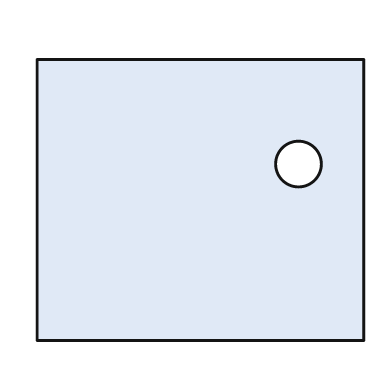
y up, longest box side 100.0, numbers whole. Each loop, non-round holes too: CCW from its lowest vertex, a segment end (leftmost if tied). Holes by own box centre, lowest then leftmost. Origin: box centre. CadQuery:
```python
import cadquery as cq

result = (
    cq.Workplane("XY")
    .moveTo(-50.0, -43.0)
    .lineTo(50.0, -43.0)
    .lineTo(50.0, 43.0)
    .lineTo(-50.0, 43.0)
    .close()
    .moveTo(30.0, 11.0)
    .circle(7.0)
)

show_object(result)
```